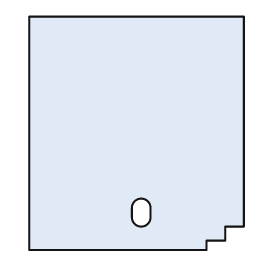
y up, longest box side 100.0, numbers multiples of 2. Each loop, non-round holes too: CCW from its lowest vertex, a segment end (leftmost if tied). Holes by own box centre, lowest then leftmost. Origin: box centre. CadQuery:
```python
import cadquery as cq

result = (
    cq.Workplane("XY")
    .moveTo(-46.0, -50.0)
    .lineTo(30.0, -50.0)
    .lineTo(30.0, -46.0)
    .lineTo(38.0, -46.0)
    .lineTo(38.0, -40.0)
    .lineTo(46.0, -40.0)
    .lineTo(46.0, 50.0)
    .lineTo(-46.0, 50.0)
    .close()
    .moveTo(-2.0, -36.0)
    .threePointArc((2.0, -40.0), (6.0, -36.0))
    .lineTo(6.0, -32.0)
    .threePointArc((2.0, -28.0), (-2.0, -32.0))
    .close()
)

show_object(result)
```